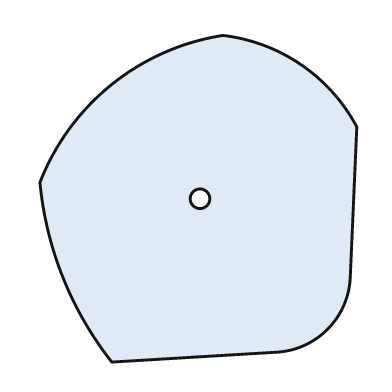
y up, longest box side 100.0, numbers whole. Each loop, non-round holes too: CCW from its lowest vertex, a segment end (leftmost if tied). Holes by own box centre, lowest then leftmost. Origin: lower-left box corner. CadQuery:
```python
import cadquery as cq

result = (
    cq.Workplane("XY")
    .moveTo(22.0, 0.0)
    .lineTo(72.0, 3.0)
    .threePointArc((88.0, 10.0), (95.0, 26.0))
    .lineTo(97.0, 72.0)
    .threePointArc((80.0, 91.0), (56.0, 100.0))
    .threePointArc((22.0, 85.0), (0.0, 55.0))
    .threePointArc((7.0, 26.0), (22.0, 0.0))
    .close()
    .moveTo(49.0, 50.0)
    .circle(3.0)
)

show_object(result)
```